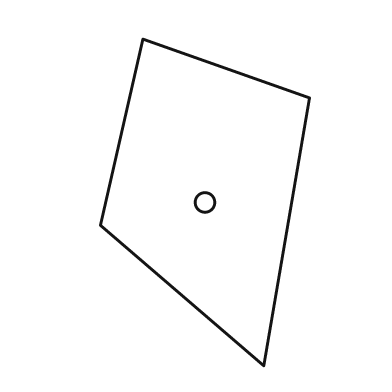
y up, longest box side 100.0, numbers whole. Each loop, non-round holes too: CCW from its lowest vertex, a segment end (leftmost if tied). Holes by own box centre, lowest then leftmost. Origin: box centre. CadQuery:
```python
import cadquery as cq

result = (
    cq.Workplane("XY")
    .moveTo(18.0, -50.0)
    .lineTo(32.0, 32.0)
    .lineTo(-19.0, 50.0)
    .lineTo(-32.0, -7.0)
    .close()
    .moveTo(0.0, 0.0)
    .circle(3.0)
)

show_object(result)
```